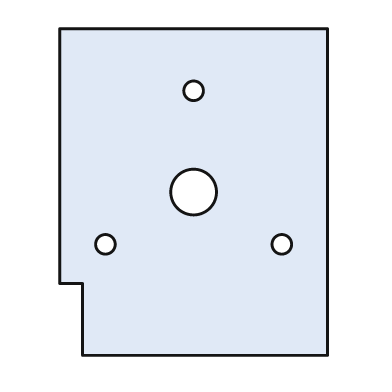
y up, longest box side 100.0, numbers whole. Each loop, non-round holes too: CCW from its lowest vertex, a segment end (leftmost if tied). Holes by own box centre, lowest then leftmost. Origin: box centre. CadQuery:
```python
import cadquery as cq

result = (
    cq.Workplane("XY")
    .moveTo(-34.0, -50.0)
    .lineTo(41.0, -50.0)
    .lineTo(41.0, 50.0)
    .lineTo(-41.0, 50.0)
    .lineTo(-41.0, -28.0)
    .lineTo(-34.0, -28.0)
    .close()
    .moveTo(-27.0, -16.0)
    .circle(3.0)
    .moveTo(27.0, -16.0)
    .circle(3.0)
    .moveTo(0.0, 0.0)
    .circle(7.0)
    .moveTo(0.0, 31.0)
    .circle(3.0)
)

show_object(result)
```